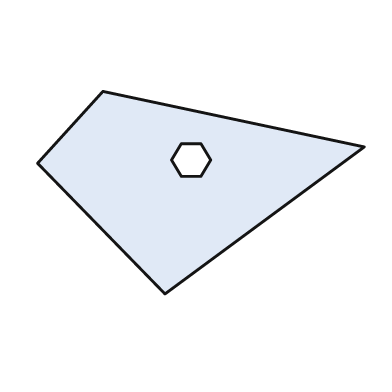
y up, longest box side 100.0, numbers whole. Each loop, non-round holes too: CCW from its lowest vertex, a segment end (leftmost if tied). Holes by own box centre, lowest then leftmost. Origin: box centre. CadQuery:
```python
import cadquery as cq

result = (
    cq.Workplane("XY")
    .moveTo(-11.0, -31.0)
    .lineTo(50.0, 14.0)
    .lineTo(-30.0, 31.0)
    .lineTo(-50.0, 9.0)
    .close()
    .moveTo(-6.0, 5.0)
    .lineTo(0.0, 5.0)
    .lineTo(3.0, 10.0)
    .lineTo(0.0, 15.0)
    .lineTo(-6.0, 15.0)
    .lineTo(-9.0, 10.0)
    .close()
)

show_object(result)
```